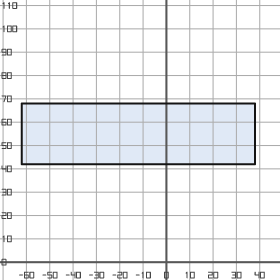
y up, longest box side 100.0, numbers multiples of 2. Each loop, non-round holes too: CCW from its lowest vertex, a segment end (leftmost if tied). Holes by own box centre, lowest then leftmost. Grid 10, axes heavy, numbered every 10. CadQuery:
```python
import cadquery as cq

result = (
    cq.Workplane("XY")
    .moveTo(-62.0, 42.0)
    .lineTo(38.0, 42.0)
    .lineTo(38.0, 68.0)
    .lineTo(-62.0, 68.0)
    .close()
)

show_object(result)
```